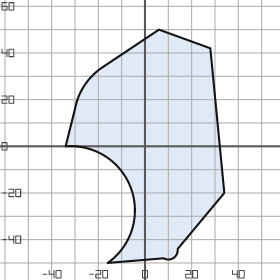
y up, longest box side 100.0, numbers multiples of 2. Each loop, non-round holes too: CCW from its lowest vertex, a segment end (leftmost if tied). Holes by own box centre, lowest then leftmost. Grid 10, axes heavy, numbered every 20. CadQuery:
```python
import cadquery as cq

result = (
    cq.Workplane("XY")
    .moveTo(-16.0, -50.0)
    .lineTo(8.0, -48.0)
    .threePointArc((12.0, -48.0), (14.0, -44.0))
    .lineTo(34.0, -20.0)
    .lineTo(28.0, 42.0)
    .lineTo(6.0, 50.0)
    .lineTo(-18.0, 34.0)
    .threePointArc((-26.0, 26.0), (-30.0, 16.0))
    .lineTo(-34.0, 0.0)
    .threePointArc((-6.0, -18.0), (-16.0, -50.0))
    .close()
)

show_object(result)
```